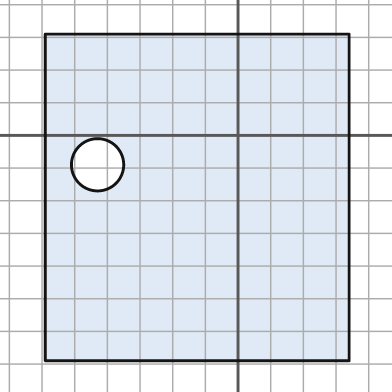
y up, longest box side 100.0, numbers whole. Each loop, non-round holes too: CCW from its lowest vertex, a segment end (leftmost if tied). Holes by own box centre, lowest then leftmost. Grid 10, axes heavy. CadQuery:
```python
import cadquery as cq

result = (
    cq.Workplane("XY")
    .moveTo(-59.0, -69.0)
    .lineTo(34.0, -69.0)
    .lineTo(34.0, 31.0)
    .lineTo(-59.0, 31.0)
    .close()
    .moveTo(-43.0, -9.0)
    .circle(8.0)
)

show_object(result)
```